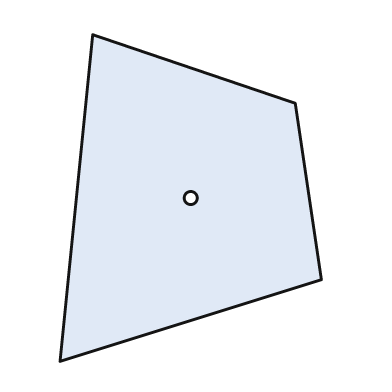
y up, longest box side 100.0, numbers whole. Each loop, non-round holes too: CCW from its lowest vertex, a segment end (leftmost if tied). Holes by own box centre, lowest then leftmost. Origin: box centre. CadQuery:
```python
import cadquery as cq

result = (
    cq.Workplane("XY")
    .moveTo(-40.0, -50.0)
    .lineTo(40.0, -25.0)
    .lineTo(32.0, 29.0)
    .lineTo(-30.0, 50.0)
    .close()
    .moveTo(0.0, 0.0)
    .circle(2.0)
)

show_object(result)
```